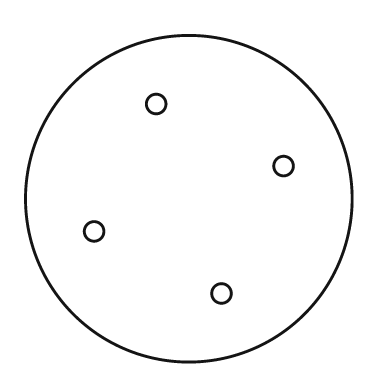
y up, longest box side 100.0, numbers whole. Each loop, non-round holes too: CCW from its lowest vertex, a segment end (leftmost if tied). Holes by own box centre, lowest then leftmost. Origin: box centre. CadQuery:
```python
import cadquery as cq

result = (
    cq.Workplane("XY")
    .moveTo(0.0, 0.0)
    .circle(50.0)
    .moveTo(10.0, -29.0)
    .circle(3.0)
    .moveTo(-29.0, -10.0)
    .circle(3.0)
    .moveTo(29.0, 10.0)
    .circle(3.0)
    .moveTo(-10.0, 29.0)
    .circle(3.0)
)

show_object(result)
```